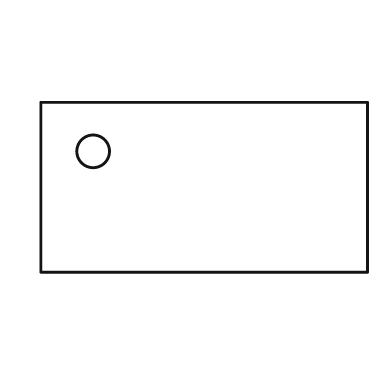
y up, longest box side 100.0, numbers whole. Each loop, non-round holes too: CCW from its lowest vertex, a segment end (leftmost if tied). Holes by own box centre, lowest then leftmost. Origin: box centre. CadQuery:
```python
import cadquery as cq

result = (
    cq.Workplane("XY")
    .moveTo(-50.0, -26.0)
    .lineTo(50.0, -26.0)
    .lineTo(50.0, 26.0)
    .lineTo(-50.0, 26.0)
    .close()
    .moveTo(-34.0, 11.0)
    .circle(5.0)
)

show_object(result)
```